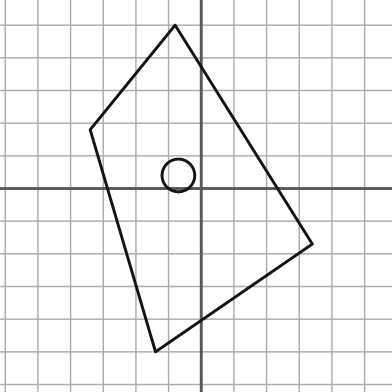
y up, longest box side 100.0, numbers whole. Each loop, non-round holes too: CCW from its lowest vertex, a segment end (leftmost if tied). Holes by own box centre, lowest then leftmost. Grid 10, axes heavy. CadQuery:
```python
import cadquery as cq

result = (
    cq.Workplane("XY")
    .moveTo(-14.0, -50.0)
    .lineTo(34.0, -17.0)
    .lineTo(-8.0, 50.0)
    .lineTo(-34.0, 18.0)
    .close()
    .moveTo(-7.0, 4.0)
    .circle(5.0)
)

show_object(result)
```